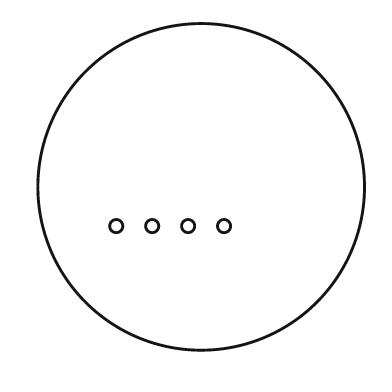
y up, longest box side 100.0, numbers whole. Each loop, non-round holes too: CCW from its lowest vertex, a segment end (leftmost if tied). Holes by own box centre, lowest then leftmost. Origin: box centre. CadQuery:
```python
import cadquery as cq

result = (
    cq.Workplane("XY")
    .moveTo(0.0, 0.0)
    .circle(50.0)
    .moveTo(-26.0, -12.0)
    .circle(2.0)
    .moveTo(-15.0, -12.0)
    .circle(2.0)
    .moveTo(-4.0, -12.0)
    .circle(2.0)
    .moveTo(7.0, -12.0)
    .circle(2.0)
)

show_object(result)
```